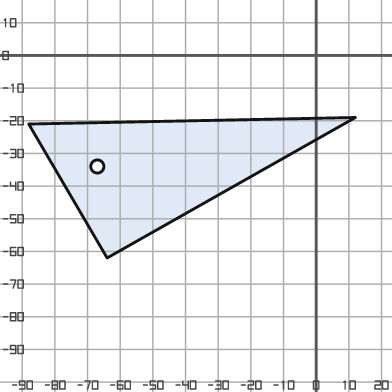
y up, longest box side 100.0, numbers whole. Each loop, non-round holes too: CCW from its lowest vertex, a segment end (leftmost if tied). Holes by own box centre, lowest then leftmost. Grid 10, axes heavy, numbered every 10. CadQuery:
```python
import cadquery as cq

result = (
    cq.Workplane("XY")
    .moveTo(-64.0, -62.0)
    .lineTo(12.0, -19.0)
    .lineTo(-88.0, -21.0)
    .close()
    .moveTo(-67.0, -34.0)
    .circle(2.0)
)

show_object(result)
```